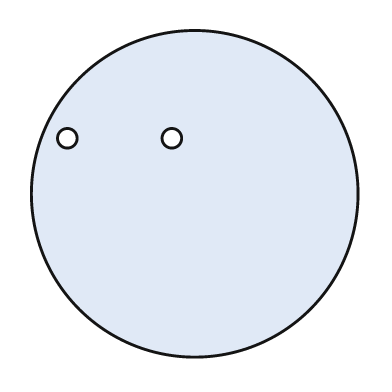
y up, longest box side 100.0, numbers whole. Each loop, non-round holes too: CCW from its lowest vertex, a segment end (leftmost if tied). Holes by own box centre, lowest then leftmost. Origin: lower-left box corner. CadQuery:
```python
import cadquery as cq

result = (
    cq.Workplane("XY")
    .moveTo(50.0, 50.0)
    .circle(50.0)
    .moveTo(11.0, 67.0)
    .circle(3.0)
    .moveTo(43.0, 67.0)
    .circle(3.0)
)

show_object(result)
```